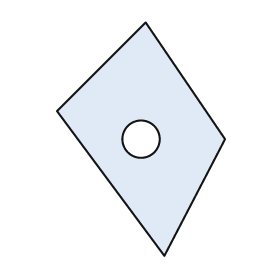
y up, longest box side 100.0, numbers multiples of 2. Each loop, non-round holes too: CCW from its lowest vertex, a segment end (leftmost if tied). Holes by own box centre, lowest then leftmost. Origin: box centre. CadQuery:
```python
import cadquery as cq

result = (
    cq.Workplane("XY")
    .moveTo(10.0, -50.0)
    .lineTo(36.0, 0.0)
    .lineTo(2.0, 50.0)
    .lineTo(-36.0, 12.0)
    .close()
    .moveTo(0.0, 0.0)
    .circle(8.0)
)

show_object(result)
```